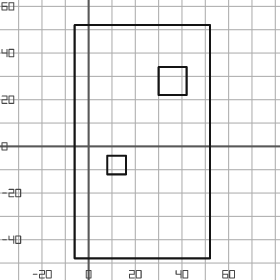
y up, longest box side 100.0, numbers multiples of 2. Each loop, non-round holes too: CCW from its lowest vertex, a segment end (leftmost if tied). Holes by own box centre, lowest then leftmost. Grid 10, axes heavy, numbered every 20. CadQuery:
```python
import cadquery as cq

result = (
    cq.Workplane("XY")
    .moveTo(-6.0, -48.0)
    .lineTo(52.0, -48.0)
    .lineTo(52.0, 52.0)
    .lineTo(-6.0, 52.0)
    .close()
    .moveTo(8.0, -12.0)
    .lineTo(16.0, -12.0)
    .lineTo(16.0, -4.0)
    .lineTo(8.0, -4.0)
    .close()
    .moveTo(30.0, 22.0)
    .lineTo(42.0, 22.0)
    .lineTo(42.0, 34.0)
    .lineTo(30.0, 34.0)
    .close()
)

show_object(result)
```